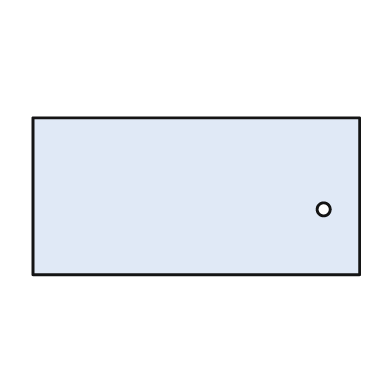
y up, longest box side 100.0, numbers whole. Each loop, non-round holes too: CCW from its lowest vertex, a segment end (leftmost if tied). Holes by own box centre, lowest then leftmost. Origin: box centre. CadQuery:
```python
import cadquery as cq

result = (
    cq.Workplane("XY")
    .moveTo(-50.0, -24.0)
    .lineTo(50.0, -24.0)
    .lineTo(50.0, 24.0)
    .lineTo(-50.0, 24.0)
    .close()
    .moveTo(39.0, -4.0)
    .circle(2.0)
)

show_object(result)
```